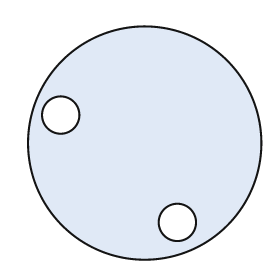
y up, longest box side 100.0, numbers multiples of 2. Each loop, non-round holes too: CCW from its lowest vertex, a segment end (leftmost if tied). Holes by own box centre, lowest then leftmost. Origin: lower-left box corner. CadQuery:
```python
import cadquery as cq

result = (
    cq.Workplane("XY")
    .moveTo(50.0, 50.0)
    .circle(50.0)
    .moveTo(64.0, 16.0)
    .circle(8.0)
    .moveTo(14.0, 62.0)
    .circle(8.0)
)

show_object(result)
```